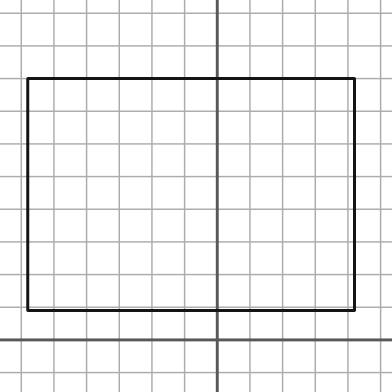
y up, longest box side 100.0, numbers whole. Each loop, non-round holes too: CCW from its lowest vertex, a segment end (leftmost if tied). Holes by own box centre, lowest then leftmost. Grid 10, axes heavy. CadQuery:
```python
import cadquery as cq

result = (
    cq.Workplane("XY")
    .moveTo(-58.0, 9.0)
    .lineTo(42.0, 9.0)
    .lineTo(42.0, 80.0)
    .lineTo(-58.0, 80.0)
    .close()
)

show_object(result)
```